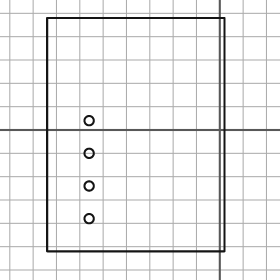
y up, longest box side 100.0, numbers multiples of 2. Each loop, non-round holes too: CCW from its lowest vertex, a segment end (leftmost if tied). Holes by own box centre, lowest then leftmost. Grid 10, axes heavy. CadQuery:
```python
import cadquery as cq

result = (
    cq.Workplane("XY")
    .moveTo(-74.0, -52.0)
    .lineTo(2.0, -52.0)
    .lineTo(2.0, 48.0)
    .lineTo(-74.0, 48.0)
    .close()
    .moveTo(-56.0, -38.0)
    .circle(2.0)
    .moveTo(-56.0, -24.0)
    .circle(2.0)
    .moveTo(-56.0, -10.0)
    .circle(2.0)
    .moveTo(-56.0, 4.0)
    .circle(2.0)
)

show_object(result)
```